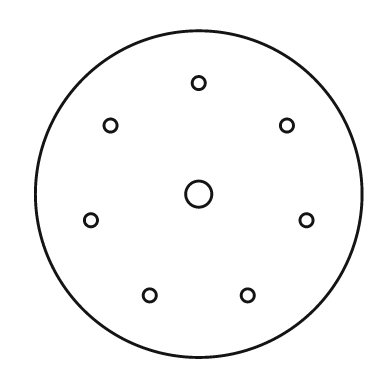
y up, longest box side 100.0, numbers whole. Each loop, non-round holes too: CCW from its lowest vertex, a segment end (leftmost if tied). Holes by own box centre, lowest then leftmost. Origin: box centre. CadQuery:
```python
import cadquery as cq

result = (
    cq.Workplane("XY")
    .moveTo(0.0, 0.0)
    .circle(50.0)
    .moveTo(-15.0, -31.0)
    .circle(2.0)
    .moveTo(15.0, -31.0)
    .circle(2.0)
    .moveTo(-33.0, -8.0)
    .circle(2.0)
    .moveTo(33.0, -8.0)
    .circle(2.0)
    .moveTo(0.0, 0.0)
    .circle(4.0)
    .moveTo(-27.0, 21.0)
    .circle(2.0)
    .moveTo(27.0, 21.0)
    .circle(2.0)
    .moveTo(0.0, 34.0)
    .circle(2.0)
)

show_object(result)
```